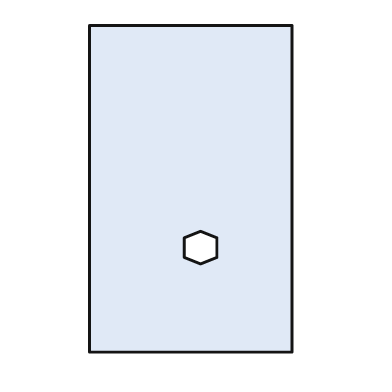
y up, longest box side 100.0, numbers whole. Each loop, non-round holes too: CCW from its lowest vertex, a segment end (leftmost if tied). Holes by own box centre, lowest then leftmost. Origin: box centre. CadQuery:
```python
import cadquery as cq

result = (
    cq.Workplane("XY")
    .moveTo(-31.0, -50.0)
    .lineTo(31.0, -50.0)
    .lineTo(31.0, 50.0)
    .lineTo(-31.0, 50.0)
    .close()
    .moveTo(3.0, -23.0)
    .lineTo(8.0, -21.0)
    .lineTo(8.0, -15.0)
    .lineTo(3.0, -13.0)
    .lineTo(-2.0, -15.0)
    .lineTo(-2.0, -21.0)
    .close()
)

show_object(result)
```